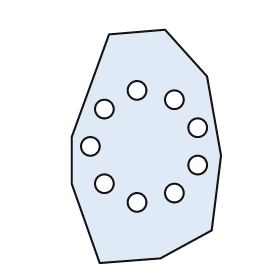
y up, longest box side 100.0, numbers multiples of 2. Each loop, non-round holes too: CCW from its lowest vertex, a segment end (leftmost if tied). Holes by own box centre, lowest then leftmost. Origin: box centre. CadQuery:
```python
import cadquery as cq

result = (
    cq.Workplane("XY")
    .moveTo(-20.0, -50.0)
    .lineTo(6.0, -48.0)
    .lineTo(28.0, -36.0)
    .lineTo(32.0, -4.0)
    .lineTo(26.0, 30.0)
    .lineTo(8.0, 50.0)
    .lineTo(-16.0, 48.0)
    .lineTo(-32.0, 4.0)
    .lineTo(-32.0, -16.0)
    .close()
    .moveTo(-4.0, -24.0)
    .circle(4.0)
    .moveTo(12.0, -20.0)
    .circle(4.0)
    .moveTo(-18.0, -16.0)
    .circle(4.0)
    .moveTo(22.0, -8.0)
    .circle(4.0)
    .moveTo(-24.0, 0.0)
    .circle(4.0)
    .moveTo(22.0, 8.0)
    .circle(4.0)
    .moveTo(-18.0, 16.0)
    .circle(4.0)
    .moveTo(12.0, 20.0)
    .circle(4.0)
    .moveTo(-4.0, 24.0)
    .circle(4.0)
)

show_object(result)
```